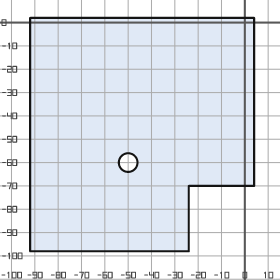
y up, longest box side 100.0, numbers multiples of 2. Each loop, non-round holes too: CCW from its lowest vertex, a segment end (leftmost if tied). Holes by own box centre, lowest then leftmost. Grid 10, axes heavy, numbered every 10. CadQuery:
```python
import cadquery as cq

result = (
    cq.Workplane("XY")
    .moveTo(-92.0, -98.0)
    .lineTo(-24.0, -98.0)
    .lineTo(-24.0, -70.0)
    .lineTo(4.0, -70.0)
    .lineTo(4.0, 2.0)
    .lineTo(-92.0, 2.0)
    .close()
    .moveTo(-50.0, -60.0)
    .circle(4.0)
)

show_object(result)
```